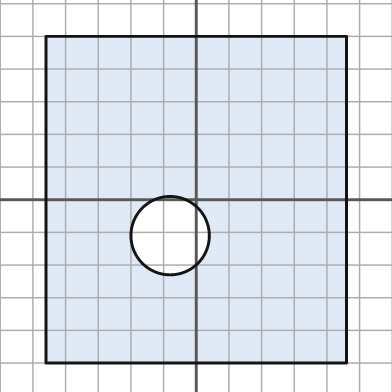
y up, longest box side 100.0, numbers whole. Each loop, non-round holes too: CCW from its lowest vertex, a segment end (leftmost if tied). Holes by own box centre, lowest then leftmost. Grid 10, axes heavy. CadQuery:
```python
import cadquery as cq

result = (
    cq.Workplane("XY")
    .moveTo(-46.0, -50.0)
    .lineTo(46.0, -50.0)
    .lineTo(46.0, 50.0)
    .lineTo(-46.0, 50.0)
    .close()
    .moveTo(-8.0, -11.0)
    .circle(12.0)
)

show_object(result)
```